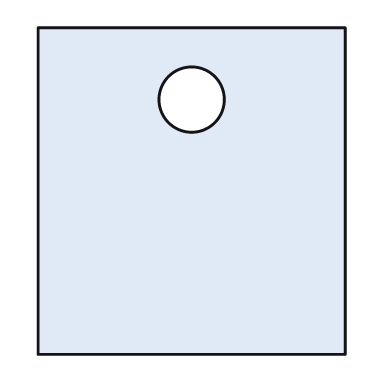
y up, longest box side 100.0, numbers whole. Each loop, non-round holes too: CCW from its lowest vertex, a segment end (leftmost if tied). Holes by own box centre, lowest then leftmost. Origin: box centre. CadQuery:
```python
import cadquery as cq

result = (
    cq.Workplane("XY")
    .moveTo(-47.0, -50.0)
    .lineTo(47.0, -50.0)
    .lineTo(47.0, 50.0)
    .lineTo(-47.0, 50.0)
    .close()
    .moveTo(0.0, 28.0)
    .circle(10.0)
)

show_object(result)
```